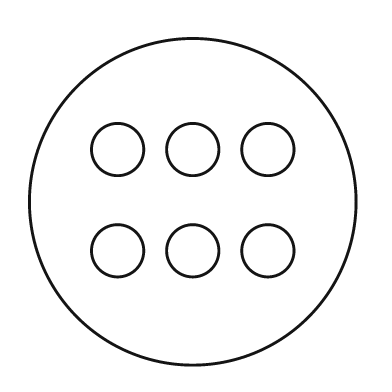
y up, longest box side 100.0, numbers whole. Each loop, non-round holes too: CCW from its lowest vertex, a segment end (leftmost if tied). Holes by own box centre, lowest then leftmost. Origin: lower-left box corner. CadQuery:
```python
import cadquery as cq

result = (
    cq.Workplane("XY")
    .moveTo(50.0, 50.0)
    .circle(50.0)
    .moveTo(27.0, 35.0)
    .circle(8.0)
    .moveTo(50.0, 35.0)
    .circle(8.0)
    .moveTo(73.0, 35.0)
    .circle(8.0)
    .moveTo(27.0, 66.0)
    .circle(8.0)
    .moveTo(50.0, 66.0)
    .circle(8.0)
    .moveTo(73.0, 66.0)
    .circle(8.0)
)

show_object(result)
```